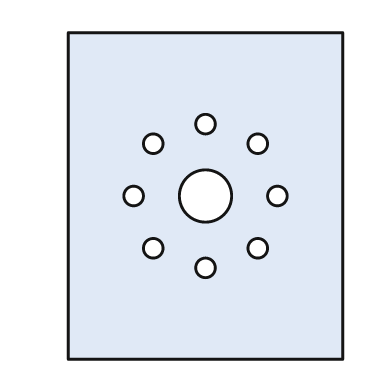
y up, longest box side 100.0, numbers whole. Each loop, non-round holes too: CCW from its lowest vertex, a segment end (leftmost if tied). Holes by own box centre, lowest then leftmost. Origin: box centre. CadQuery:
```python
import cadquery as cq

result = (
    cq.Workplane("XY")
    .moveTo(-42.0, -50.0)
    .lineTo(42.0, -50.0)
    .lineTo(42.0, 50.0)
    .lineTo(-42.0, 50.0)
    .close()
    .moveTo(0.0, -22.0)
    .circle(3.0)
    .moveTo(-16.0, -16.0)
    .circle(3.0)
    .moveTo(16.0, -16.0)
    .circle(3.0)
    .moveTo(-22.0, 0.0)
    .circle(3.0)
    .moveTo(0.0, 0.0)
    .circle(8.0)
    .moveTo(22.0, 0.0)
    .circle(3.0)
    .moveTo(-16.0, 16.0)
    .circle(3.0)
    .moveTo(16.0, 16.0)
    .circle(3.0)
    .moveTo(0.0, 22.0)
    .circle(3.0)
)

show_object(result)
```